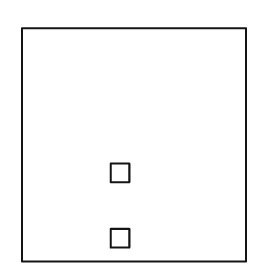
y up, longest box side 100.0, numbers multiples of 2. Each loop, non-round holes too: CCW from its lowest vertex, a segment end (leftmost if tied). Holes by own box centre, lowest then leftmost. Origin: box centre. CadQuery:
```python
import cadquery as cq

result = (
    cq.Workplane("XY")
    .moveTo(-48.0, -50.0)
    .lineTo(48.0, -50.0)
    .lineTo(48.0, 50.0)
    .lineTo(-48.0, 50.0)
    .close()
    .moveTo(-10.0, -44.0)
    .lineTo(-2.0, -44.0)
    .lineTo(-2.0, -36.0)
    .lineTo(-10.0, -36.0)
    .close()
    .moveTo(-10.0, -16.0)
    .lineTo(-2.0, -16.0)
    .lineTo(-2.0, -8.0)
    .lineTo(-10.0, -8.0)
    .close()
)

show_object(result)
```